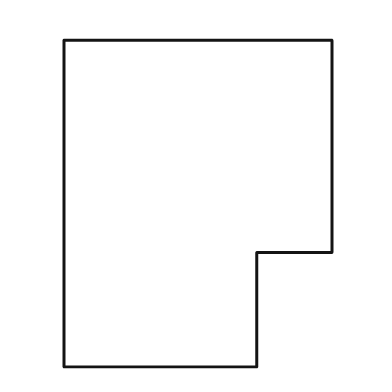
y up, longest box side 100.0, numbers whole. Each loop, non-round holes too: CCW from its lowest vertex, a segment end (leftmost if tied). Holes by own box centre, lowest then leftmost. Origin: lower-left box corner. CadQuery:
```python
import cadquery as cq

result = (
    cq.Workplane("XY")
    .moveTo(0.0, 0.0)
    .lineTo(59.0, 0.0)
    .lineTo(59.0, 35.0)
    .lineTo(82.0, 35.0)
    .lineTo(82.0, 100.0)
    .lineTo(0.0, 100.0)
    .close()
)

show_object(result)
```